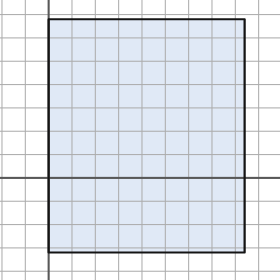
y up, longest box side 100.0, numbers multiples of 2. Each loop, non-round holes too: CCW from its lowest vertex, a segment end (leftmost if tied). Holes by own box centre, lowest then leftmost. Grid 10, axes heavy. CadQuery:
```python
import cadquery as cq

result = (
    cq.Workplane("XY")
    .moveTo(0.0, -32.0)
    .lineTo(84.0, -32.0)
    .lineTo(84.0, 68.0)
    .lineTo(0.0, 68.0)
    .close()
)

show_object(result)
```